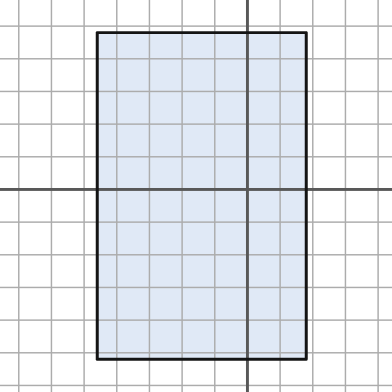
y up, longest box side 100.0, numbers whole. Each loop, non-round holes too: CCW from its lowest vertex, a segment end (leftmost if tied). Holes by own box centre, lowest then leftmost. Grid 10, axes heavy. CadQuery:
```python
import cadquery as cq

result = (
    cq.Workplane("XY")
    .moveTo(-46.0, -52.0)
    .lineTo(18.0, -52.0)
    .lineTo(18.0, 48.0)
    .lineTo(-46.0, 48.0)
    .close()
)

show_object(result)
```